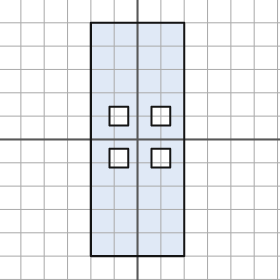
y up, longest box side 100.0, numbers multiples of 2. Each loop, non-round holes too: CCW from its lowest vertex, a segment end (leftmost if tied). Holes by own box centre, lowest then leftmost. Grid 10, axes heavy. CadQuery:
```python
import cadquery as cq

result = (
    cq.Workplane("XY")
    .moveTo(-20.0, -50.0)
    .lineTo(20.0, -50.0)
    .lineTo(20.0, 50.0)
    .lineTo(-20.0, 50.0)
    .close()
    .moveTo(-12.0, -12.0)
    .lineTo(-4.0, -12.0)
    .lineTo(-4.0, -4.0)
    .lineTo(-12.0, -4.0)
    .close()
    .moveTo(6.0, -12.0)
    .lineTo(14.0, -12.0)
    .lineTo(14.0, -4.0)
    .lineTo(6.0, -4.0)
    .close()
    .moveTo(-12.0, 6.0)
    .lineTo(-4.0, 6.0)
    .lineTo(-4.0, 14.0)
    .lineTo(-12.0, 14.0)
    .close()
    .moveTo(6.0, 6.0)
    .lineTo(14.0, 6.0)
    .lineTo(14.0, 14.0)
    .lineTo(6.0, 14.0)
    .close()
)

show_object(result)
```